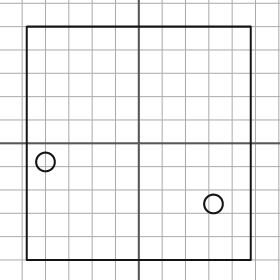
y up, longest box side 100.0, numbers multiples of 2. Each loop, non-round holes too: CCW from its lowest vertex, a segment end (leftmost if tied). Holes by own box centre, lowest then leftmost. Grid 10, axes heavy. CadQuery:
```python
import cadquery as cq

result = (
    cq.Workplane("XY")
    .moveTo(-48.0, -50.0)
    .lineTo(48.0, -50.0)
    .lineTo(48.0, 50.0)
    .lineTo(-48.0, 50.0)
    .close()
    .moveTo(32.0, -26.0)
    .circle(4.0)
    .moveTo(-40.0, -8.0)
    .circle(4.0)
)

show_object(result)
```